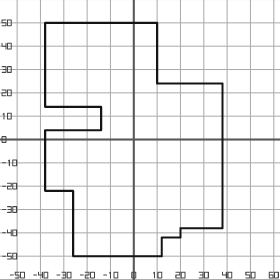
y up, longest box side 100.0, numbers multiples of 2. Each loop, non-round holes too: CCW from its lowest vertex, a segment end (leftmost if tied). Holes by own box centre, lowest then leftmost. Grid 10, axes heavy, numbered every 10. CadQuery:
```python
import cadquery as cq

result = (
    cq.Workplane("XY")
    .moveTo(-26.0, -50.0)
    .lineTo(12.0, -50.0)
    .lineTo(12.0, -42.0)
    .lineTo(20.0, -42.0)
    .lineTo(20.0, -38.0)
    .lineTo(38.0, -38.0)
    .lineTo(38.0, 24.0)
    .lineTo(10.0, 24.0)
    .lineTo(10.0, 50.0)
    .lineTo(-38.0, 50.0)
    .lineTo(-38.0, 14.0)
    .lineTo(-14.0, 14.0)
    .lineTo(-14.0, 4.0)
    .lineTo(-38.0, 4.0)
    .lineTo(-38.0, -22.0)
    .lineTo(-26.0, -22.0)
    .close()
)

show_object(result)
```